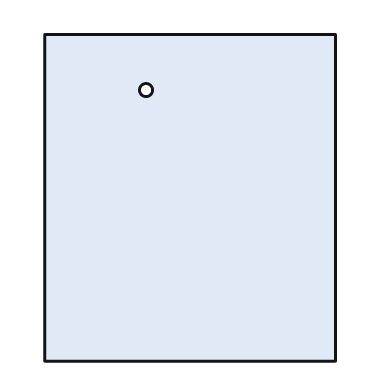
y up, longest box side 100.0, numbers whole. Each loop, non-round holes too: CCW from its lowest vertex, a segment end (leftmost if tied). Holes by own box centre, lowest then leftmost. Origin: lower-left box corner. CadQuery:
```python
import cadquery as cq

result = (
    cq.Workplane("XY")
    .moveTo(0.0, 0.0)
    .lineTo(89.0, 0.0)
    .lineTo(89.0, 100.0)
    .lineTo(0.0, 100.0)
    .close()
    .moveTo(31.0, 83.0)
    .circle(2.0)
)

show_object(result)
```